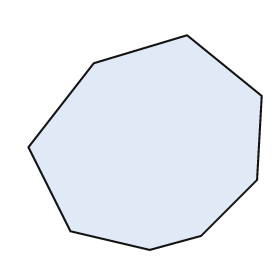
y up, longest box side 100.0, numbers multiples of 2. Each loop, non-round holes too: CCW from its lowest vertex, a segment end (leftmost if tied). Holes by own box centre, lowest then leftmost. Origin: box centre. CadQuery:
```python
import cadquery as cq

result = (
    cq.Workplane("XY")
    .moveTo(2.0, -46.0)
    .lineTo(24.0, -40.0)
    .lineTo(48.0, -16.0)
    .lineTo(50.0, 20.0)
    .lineTo(18.0, 46.0)
    .lineTo(-22.0, 34.0)
    .lineTo(-50.0, -2.0)
    .lineTo(-32.0, -38.0)
    .close()
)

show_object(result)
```